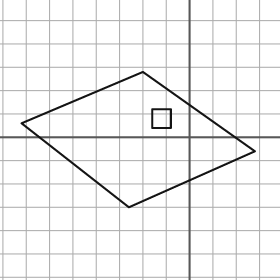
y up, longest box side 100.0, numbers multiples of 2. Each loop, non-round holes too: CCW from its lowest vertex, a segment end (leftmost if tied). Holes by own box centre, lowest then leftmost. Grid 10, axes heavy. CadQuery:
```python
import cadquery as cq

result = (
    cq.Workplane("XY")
    .moveTo(-26.0, -30.0)
    .lineTo(28.0, -6.0)
    .lineTo(-20.0, 28.0)
    .lineTo(-72.0, 6.0)
    .close()
    .moveTo(-16.0, 4.0)
    .lineTo(-8.0, 4.0)
    .lineTo(-8.0, 12.0)
    .lineTo(-16.0, 12.0)
    .close()
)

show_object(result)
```